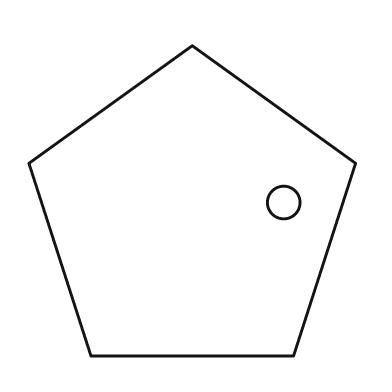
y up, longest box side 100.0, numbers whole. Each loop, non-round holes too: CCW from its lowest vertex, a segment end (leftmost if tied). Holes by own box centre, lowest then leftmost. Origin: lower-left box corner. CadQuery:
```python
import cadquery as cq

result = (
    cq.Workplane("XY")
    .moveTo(19.0, 0.0)
    .lineTo(81.0, 0.0)
    .lineTo(100.0, 59.0)
    .lineTo(50.0, 95.0)
    .lineTo(0.0, 59.0)
    .close()
    .moveTo(78.0, 47.0)
    .circle(5.0)
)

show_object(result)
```